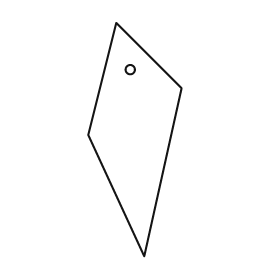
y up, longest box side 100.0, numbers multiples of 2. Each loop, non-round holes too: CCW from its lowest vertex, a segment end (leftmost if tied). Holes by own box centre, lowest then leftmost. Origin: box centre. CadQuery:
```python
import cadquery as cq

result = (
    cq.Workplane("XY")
    .moveTo(4.0, -50.0)
    .lineTo(20.0, 22.0)
    .lineTo(-8.0, 50.0)
    .lineTo(-20.0, 2.0)
    .close()
    .moveTo(-2.0, 30.0)
    .circle(2.0)
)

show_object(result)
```